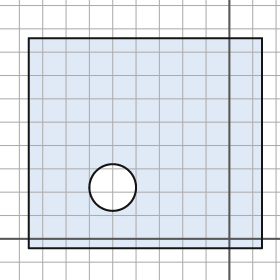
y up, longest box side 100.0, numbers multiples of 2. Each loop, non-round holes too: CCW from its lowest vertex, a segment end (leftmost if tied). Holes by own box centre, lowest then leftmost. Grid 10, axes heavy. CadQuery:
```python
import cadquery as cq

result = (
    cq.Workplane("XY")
    .moveTo(-86.0, -4.0)
    .lineTo(14.0, -4.0)
    .lineTo(14.0, 86.0)
    .lineTo(-86.0, 86.0)
    .close()
    .moveTo(-50.0, 22.0)
    .circle(10.0)
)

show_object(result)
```